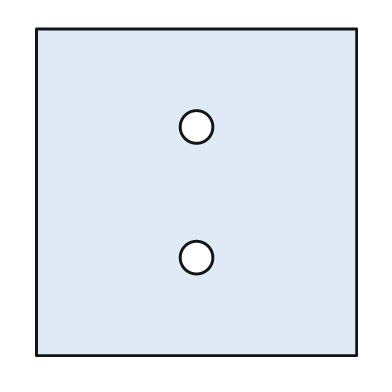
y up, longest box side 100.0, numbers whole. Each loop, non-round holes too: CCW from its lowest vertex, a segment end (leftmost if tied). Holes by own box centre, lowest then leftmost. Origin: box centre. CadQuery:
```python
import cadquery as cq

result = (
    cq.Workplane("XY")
    .moveTo(-49.0, -50.0)
    .lineTo(49.0, -50.0)
    .lineTo(49.0, 50.0)
    .lineTo(-49.0, 50.0)
    .close()
    .moveTo(0.0, -20.0)
    .circle(5.0)
    .moveTo(0.0, 20.0)
    .circle(5.0)
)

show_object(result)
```